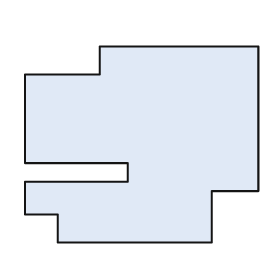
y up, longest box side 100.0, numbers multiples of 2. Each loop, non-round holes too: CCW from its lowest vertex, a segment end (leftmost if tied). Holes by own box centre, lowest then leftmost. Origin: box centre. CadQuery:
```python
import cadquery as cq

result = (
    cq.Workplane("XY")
    .moveTo(-36.0, -42.0)
    .lineTo(30.0, -42.0)
    .lineTo(30.0, -20.0)
    .lineTo(50.0, -20.0)
    .lineTo(50.0, 42.0)
    .lineTo(-18.0, 42.0)
    .lineTo(-18.0, 30.0)
    .lineTo(-50.0, 30.0)
    .lineTo(-50.0, -8.0)
    .lineTo(-6.0, -8.0)
    .lineTo(-6.0, -16.0)
    .lineTo(-50.0, -16.0)
    .lineTo(-50.0, -30.0)
    .lineTo(-36.0, -30.0)
    .close()
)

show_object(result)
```